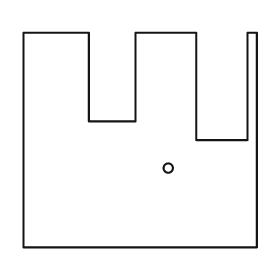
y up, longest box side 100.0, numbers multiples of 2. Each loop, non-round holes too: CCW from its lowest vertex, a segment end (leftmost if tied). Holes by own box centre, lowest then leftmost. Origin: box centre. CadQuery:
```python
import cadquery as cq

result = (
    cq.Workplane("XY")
    .moveTo(-50.0, -46.0)
    .lineTo(50.0, -46.0)
    .lineTo(50.0, 46.0)
    .lineTo(46.0, 46.0)
    .lineTo(46.0, 0.0)
    .lineTo(24.0, 0.0)
    .lineTo(24.0, 46.0)
    .lineTo(-2.0, 46.0)
    .lineTo(-2.0, 8.0)
    .lineTo(-22.0, 8.0)
    .lineTo(-22.0, 46.0)
    .lineTo(-50.0, 46.0)
    .close()
    .moveTo(12.0, -12.0)
    .circle(2.0)
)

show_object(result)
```